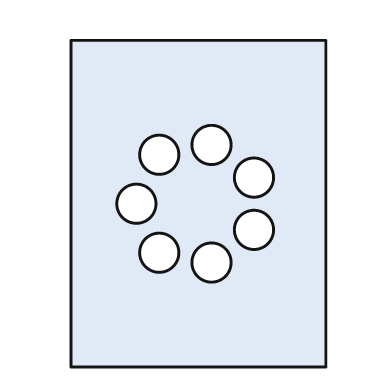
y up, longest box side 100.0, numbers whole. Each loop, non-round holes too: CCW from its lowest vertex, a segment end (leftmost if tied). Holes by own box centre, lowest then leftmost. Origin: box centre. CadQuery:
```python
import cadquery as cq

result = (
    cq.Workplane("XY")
    .moveTo(-39.0, -50.0)
    .lineTo(39.0, -50.0)
    .lineTo(39.0, 50.0)
    .lineTo(-39.0, 50.0)
    .close()
    .moveTo(4.0, -18.0)
    .circle(6.0)
    .moveTo(-12.0, -15.0)
    .circle(6.0)
    .moveTo(17.0, -8.0)
    .circle(6.0)
    .moveTo(-19.0, 0.0)
    .circle(6.0)
    .moveTo(17.0, 8.0)
    .circle(6.0)
    .moveTo(-12.0, 15.0)
    .circle(6.0)
    .moveTo(4.0, 18.0)
    .circle(6.0)
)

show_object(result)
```